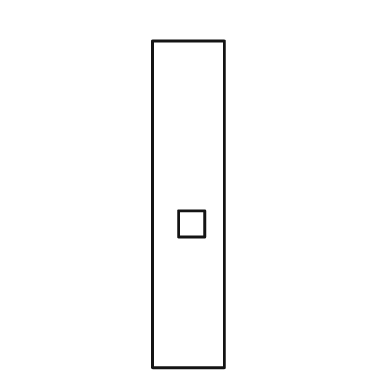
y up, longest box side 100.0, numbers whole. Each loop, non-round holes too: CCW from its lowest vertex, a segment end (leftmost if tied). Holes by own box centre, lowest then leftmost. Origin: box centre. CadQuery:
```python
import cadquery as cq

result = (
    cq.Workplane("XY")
    .moveTo(-11.0, -50.0)
    .lineTo(11.0, -50.0)
    .lineTo(11.0, 50.0)
    .lineTo(-11.0, 50.0)
    .close()
    .moveTo(-3.0, -10.0)
    .lineTo(5.0, -10.0)
    .lineTo(5.0, -2.0)
    .lineTo(-3.0, -2.0)
    .close()
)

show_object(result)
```